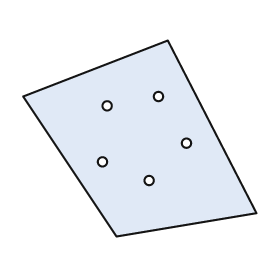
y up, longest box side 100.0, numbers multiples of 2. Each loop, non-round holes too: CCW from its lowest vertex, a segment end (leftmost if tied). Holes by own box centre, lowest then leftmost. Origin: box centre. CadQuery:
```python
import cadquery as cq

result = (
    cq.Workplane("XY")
    .moveTo(-10.0, -42.0)
    .lineTo(50.0, -32.0)
    .lineTo(12.0, 42.0)
    .lineTo(-50.0, 18.0)
    .close()
    .moveTo(4.0, -18.0)
    .circle(2.0)
    .moveTo(-16.0, -10.0)
    .circle(2.0)
    .moveTo(20.0, -2.0)
    .circle(2.0)
    .moveTo(-14.0, 14.0)
    .circle(2.0)
    .moveTo(8.0, 18.0)
    .circle(2.0)
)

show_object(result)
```